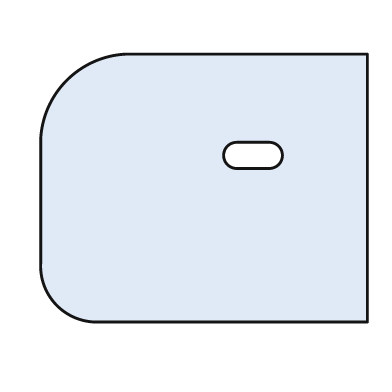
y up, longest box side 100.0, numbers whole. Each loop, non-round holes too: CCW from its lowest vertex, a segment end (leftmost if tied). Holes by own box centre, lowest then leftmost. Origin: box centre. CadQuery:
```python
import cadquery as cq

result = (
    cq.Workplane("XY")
    .moveTo(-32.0, -41.0)
    .lineTo(50.0, -41.0)
    .lineTo(50.0, 41.0)
    .lineTo(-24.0, 41.0)
    .threePointArc((-42.0, 33.0), (-50.0, 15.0))
    .lineTo(-50.0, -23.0)
    .threePointArc((-45.0, -36.0), (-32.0, -41.0))
    .close()
    .moveTo(10.0, 6.0)
    .lineTo(20.0, 6.0)
    .threePointArc((24.0, 10.0), (20.0, 14.0))
    .lineTo(10.0, 14.0)
    .threePointArc((6.0, 10.0), (10.0, 6.0))
    .close()
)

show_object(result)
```